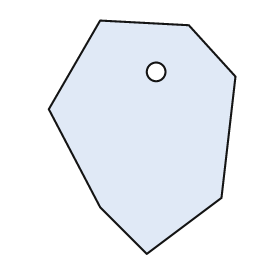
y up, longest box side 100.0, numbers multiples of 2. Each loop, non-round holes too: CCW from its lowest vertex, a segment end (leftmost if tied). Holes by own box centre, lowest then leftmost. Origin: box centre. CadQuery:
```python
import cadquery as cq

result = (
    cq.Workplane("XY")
    .moveTo(2.0, -50.0)
    .lineTo(34.0, -26.0)
    .lineTo(40.0, 26.0)
    .lineTo(20.0, 48.0)
    .lineTo(-18.0, 50.0)
    .lineTo(-40.0, 12.0)
    .lineTo(-18.0, -30.0)
    .close()
    .moveTo(6.0, 28.0)
    .circle(4.0)
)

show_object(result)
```